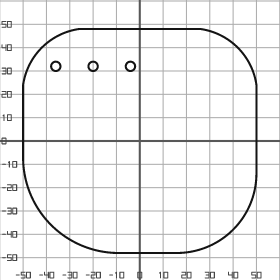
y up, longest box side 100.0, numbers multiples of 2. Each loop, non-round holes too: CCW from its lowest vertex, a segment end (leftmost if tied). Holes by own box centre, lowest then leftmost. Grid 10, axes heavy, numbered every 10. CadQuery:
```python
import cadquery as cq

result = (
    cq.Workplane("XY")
    .moveTo(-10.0, -48.0)
    .lineTo(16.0, -48.0)
    .threePointArc((40.0, -38.0), (50.0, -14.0))
    .lineTo(50.0, 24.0)
    .threePointArc((42.0, 40.0), (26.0, 48.0))
    .lineTo(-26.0, 48.0)
    .threePointArc((-42.0, 40.0), (-50.0, 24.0))
    .lineTo(-50.0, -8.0)
    .threePointArc((-38.0, -36.0), (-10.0, -48.0))
    .close()
    .moveTo(-36.0, 32.0)
    .circle(2.0)
    .moveTo(-20.0, 32.0)
    .circle(2.0)
    .moveTo(-4.0, 32.0)
    .circle(2.0)
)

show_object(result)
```